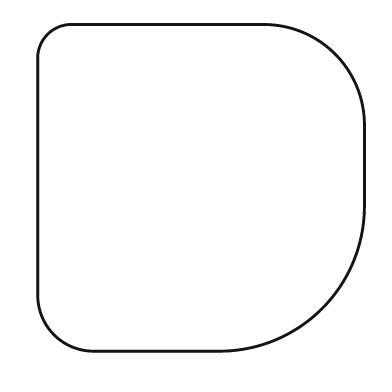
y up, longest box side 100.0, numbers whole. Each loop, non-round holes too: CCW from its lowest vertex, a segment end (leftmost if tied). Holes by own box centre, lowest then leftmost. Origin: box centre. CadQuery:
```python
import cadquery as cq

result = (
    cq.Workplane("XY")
    .moveTo(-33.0, -50.0)
    .lineTo(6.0, -50.0)
    .threePointArc((37.0, -37.0), (50.0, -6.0))
    .lineTo(50.0, 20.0)
    .threePointArc((41.0, 41.0), (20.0, 50.0))
    .lineTo(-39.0, 50.0)
    .threePointArc((-47.0, 47.0), (-50.0, 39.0))
    .lineTo(-50.0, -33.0)
    .threePointArc((-45.0, -45.0), (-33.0, -50.0))
    .close()
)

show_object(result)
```